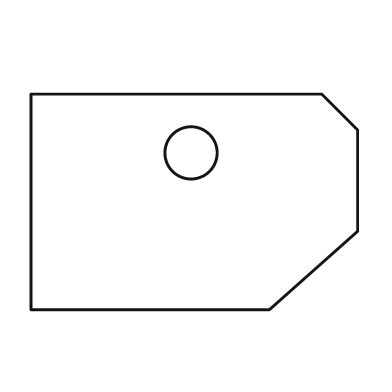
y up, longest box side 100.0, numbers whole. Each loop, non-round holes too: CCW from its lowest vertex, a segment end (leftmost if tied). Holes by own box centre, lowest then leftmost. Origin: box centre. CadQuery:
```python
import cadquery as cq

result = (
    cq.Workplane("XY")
    .moveTo(-50.0, -33.0)
    .lineTo(23.0, -33.0)
    .lineTo(50.0, -9.0)
    .lineTo(50.0, 22.0)
    .lineTo(39.0, 33.0)
    .lineTo(-50.0, 33.0)
    .close()
    .moveTo(-1.0, 15.0)
    .circle(8.0)
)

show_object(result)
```